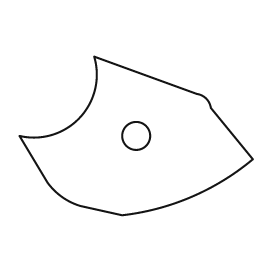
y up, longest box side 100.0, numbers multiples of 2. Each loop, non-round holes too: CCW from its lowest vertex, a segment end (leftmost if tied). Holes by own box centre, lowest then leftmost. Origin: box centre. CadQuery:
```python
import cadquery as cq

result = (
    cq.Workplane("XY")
    .moveTo(-6.0, -34.0)
    .threePointArc((24.0, -26.0), (50.0, -10.0))
    .lineTo(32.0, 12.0)
    .threePointArc((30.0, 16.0), (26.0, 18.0))
    .lineTo(-18.0, 34.0)
    .threePointArc((-24.0, 8.0), (-50.0, 0.0))
    .lineTo(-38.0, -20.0)
    .threePointArc((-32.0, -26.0), (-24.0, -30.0))
    .close()
    .moveTo(0.0, 0.0)
    .circle(6.0)
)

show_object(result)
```